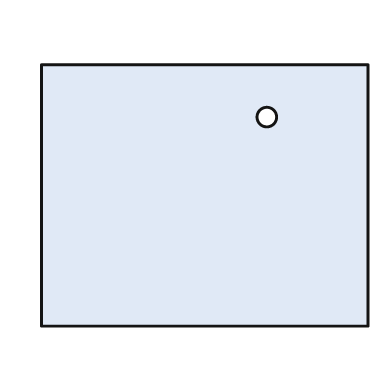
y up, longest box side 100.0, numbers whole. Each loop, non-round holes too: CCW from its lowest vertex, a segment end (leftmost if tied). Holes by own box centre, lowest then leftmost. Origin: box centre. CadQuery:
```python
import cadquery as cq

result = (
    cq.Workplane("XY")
    .moveTo(-50.0, -40.0)
    .lineTo(50.0, -40.0)
    .lineTo(50.0, 40.0)
    .lineTo(-50.0, 40.0)
    .close()
    .moveTo(19.0, 24.0)
    .circle(3.0)
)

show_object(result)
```